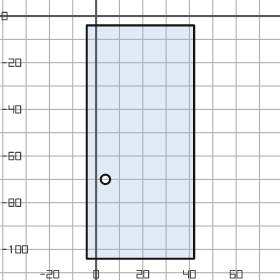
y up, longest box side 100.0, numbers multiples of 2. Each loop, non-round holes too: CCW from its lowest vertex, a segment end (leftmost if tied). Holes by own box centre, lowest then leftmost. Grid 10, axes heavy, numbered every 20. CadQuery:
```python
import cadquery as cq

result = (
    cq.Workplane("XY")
    .moveTo(-4.0, -104.0)
    .lineTo(42.0, -104.0)
    .lineTo(42.0, -4.0)
    .lineTo(-4.0, -4.0)
    .close()
    .moveTo(4.0, -70.0)
    .circle(2.0)
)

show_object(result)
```